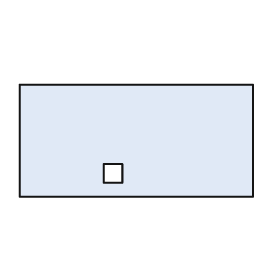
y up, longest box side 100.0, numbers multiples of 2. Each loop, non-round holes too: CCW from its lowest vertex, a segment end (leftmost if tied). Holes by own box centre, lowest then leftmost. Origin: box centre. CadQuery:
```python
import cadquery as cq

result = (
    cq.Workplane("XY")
    .moveTo(-50.0, -24.0)
    .lineTo(50.0, -24.0)
    .lineTo(50.0, 24.0)
    .lineTo(-50.0, 24.0)
    .close()
    .moveTo(-14.0, -18.0)
    .lineTo(-6.0, -18.0)
    .lineTo(-6.0, -10.0)
    .lineTo(-14.0, -10.0)
    .close()
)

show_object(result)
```